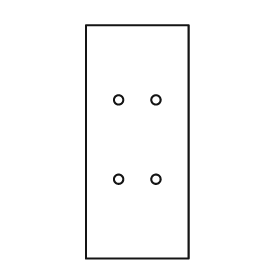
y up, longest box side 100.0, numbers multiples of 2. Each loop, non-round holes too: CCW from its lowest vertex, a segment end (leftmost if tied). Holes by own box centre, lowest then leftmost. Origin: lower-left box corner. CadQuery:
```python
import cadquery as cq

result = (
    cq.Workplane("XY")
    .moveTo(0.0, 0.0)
    .lineTo(44.0, 0.0)
    .lineTo(44.0, 100.0)
    .lineTo(0.0, 100.0)
    .close()
    .moveTo(14.0, 34.0)
    .circle(2.0)
    .moveTo(30.0, 34.0)
    .circle(2.0)
    .moveTo(14.0, 68.0)
    .circle(2.0)
    .moveTo(30.0, 68.0)
    .circle(2.0)
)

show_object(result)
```